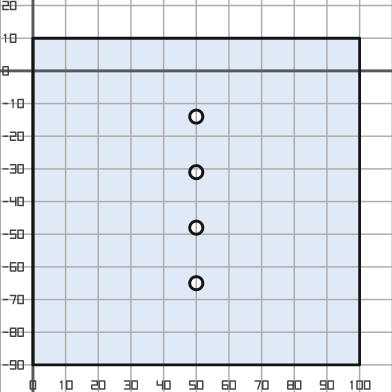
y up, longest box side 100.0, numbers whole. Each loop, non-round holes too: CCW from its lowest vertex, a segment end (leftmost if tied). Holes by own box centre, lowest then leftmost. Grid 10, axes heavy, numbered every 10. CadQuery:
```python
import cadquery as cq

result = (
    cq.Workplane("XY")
    .moveTo(0.0, -90.0)
    .lineTo(100.0, -90.0)
    .lineTo(100.0, 10.0)
    .lineTo(0.0, 10.0)
    .close()
    .moveTo(50.0, -65.0)
    .circle(2.0)
    .moveTo(50.0, -48.0)
    .circle(2.0)
    .moveTo(50.0, -31.0)
    .circle(2.0)
    .moveTo(50.0, -14.0)
    .circle(2.0)
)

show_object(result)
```